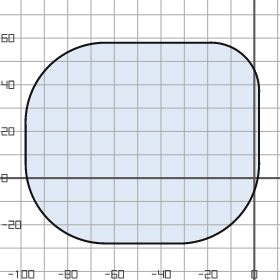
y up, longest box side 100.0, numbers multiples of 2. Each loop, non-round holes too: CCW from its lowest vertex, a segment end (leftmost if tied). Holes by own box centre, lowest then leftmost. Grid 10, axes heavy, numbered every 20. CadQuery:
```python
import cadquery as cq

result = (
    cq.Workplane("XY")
    .moveTo(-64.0, -28.0)
    .lineTo(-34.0, -28.0)
    .threePointArc((-8.0, -18.0), (2.0, 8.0))
    .lineTo(2.0, 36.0)
    .threePointArc((-4.0, 52.0), (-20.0, 58.0))
    .lineTo(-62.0, 58.0)
    .threePointArc((-88.0, 48.0), (-98.0, 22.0))
    .lineTo(-98.0, 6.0)
    .threePointArc((-88.0, -18.0), (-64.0, -28.0))
    .close()
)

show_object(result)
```